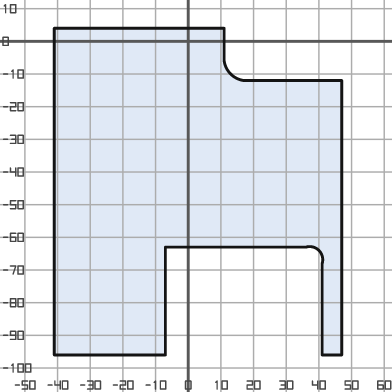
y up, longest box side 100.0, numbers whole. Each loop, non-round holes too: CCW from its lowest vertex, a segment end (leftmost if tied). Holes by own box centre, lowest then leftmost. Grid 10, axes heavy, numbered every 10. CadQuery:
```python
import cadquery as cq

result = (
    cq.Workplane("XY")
    .moveTo(-41.0, -96.0)
    .lineTo(-7.0, -96.0)
    .lineTo(-7.0, -63.0)
    .lineTo(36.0, -63.0)
    .threePointArc((40.0, -64.0), (41.0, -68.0))
    .lineTo(41.0, -96.0)
    .lineTo(47.0, -96.0)
    .lineTo(47.0, -12.0)
    .lineTo(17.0, -12.0)
    .threePointArc((13.0, -10.0), (11.0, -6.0))
    .lineTo(11.0, 4.0)
    .lineTo(-41.0, 4.0)
    .close()
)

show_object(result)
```